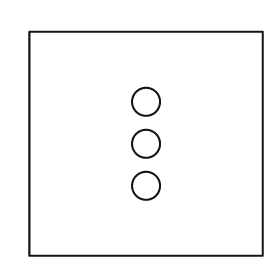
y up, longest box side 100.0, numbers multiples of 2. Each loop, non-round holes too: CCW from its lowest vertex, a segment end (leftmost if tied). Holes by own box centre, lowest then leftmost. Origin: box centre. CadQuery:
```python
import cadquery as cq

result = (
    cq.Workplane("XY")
    .moveTo(-50.0, -48.0)
    .lineTo(50.0, -48.0)
    .lineTo(50.0, 48.0)
    .lineTo(-50.0, 48.0)
    .close()
    .moveTo(0.0, -18.0)
    .circle(6.0)
    .moveTo(0.0, 0.0)
    .circle(6.0)
    .moveTo(0.0, 18.0)
    .circle(6.0)
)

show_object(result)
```